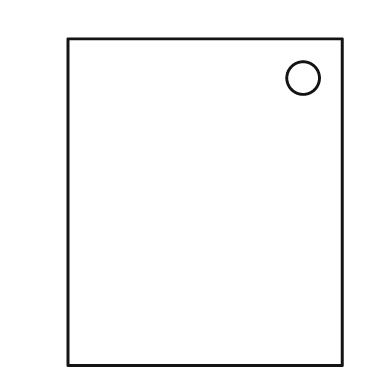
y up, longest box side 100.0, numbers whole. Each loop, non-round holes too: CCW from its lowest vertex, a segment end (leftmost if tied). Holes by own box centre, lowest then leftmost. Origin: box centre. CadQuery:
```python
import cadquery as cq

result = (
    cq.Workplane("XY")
    .moveTo(-42.0, -50.0)
    .lineTo(42.0, -50.0)
    .lineTo(42.0, 50.0)
    .lineTo(-42.0, 50.0)
    .close()
    .moveTo(30.0, 38.0)
    .circle(5.0)
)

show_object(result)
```